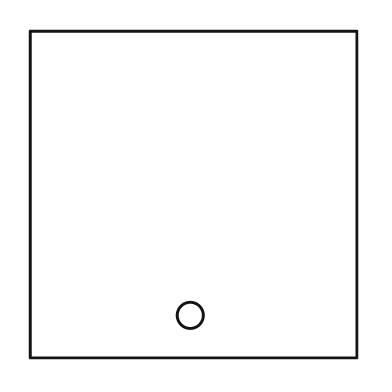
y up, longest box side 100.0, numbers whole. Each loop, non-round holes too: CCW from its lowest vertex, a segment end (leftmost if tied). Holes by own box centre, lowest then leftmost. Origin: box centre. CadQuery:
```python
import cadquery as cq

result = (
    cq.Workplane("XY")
    .moveTo(-50.0, -50.0)
    .lineTo(50.0, -50.0)
    .lineTo(50.0, 50.0)
    .lineTo(-50.0, 50.0)
    .close()
    .moveTo(-1.0, -37.0)
    .circle(4.0)
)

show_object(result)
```